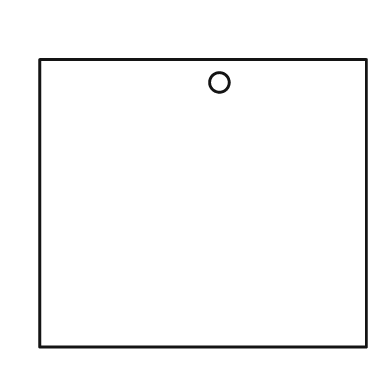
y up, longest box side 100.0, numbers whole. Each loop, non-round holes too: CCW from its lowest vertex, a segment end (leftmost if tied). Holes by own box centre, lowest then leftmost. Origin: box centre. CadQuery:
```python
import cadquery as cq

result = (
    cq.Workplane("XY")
    .moveTo(-50.0, -44.0)
    .lineTo(50.0, -44.0)
    .lineTo(50.0, 44.0)
    .lineTo(-50.0, 44.0)
    .close()
    .moveTo(5.0, 37.0)
    .circle(3.0)
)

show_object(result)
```